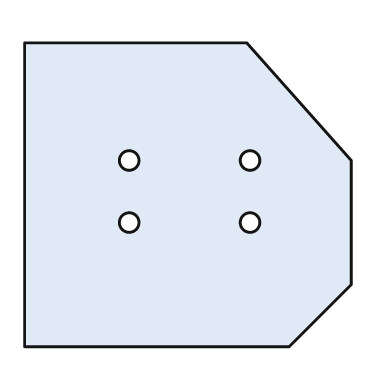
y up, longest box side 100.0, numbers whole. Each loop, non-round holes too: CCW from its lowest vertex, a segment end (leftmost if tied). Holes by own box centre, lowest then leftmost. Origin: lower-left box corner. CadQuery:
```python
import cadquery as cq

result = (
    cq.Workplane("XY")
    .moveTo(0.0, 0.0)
    .lineTo(81.0, 0.0)
    .lineTo(100.0, 19.0)
    .lineTo(100.0, 57.0)
    .lineTo(68.0, 93.0)
    .lineTo(0.0, 93.0)
    .close()
    .moveTo(32.0, 38.0)
    .circle(3.0)
    .moveTo(69.0, 38.0)
    .circle(3.0)
    .moveTo(32.0, 57.0)
    .circle(3.0)
    .moveTo(69.0, 57.0)
    .circle(3.0)
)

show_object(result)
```